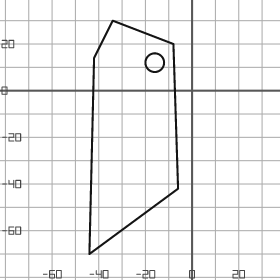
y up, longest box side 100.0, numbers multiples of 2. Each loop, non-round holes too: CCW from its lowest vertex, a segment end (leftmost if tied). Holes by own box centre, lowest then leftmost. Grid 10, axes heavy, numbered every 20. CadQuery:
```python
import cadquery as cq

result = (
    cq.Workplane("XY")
    .moveTo(-44.0, -70.0)
    .lineTo(-6.0, -42.0)
    .lineTo(-8.0, 20.0)
    .lineTo(-34.0, 30.0)
    .lineTo(-42.0, 14.0)
    .close()
    .moveTo(-16.0, 12.0)
    .circle(4.0)
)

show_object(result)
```